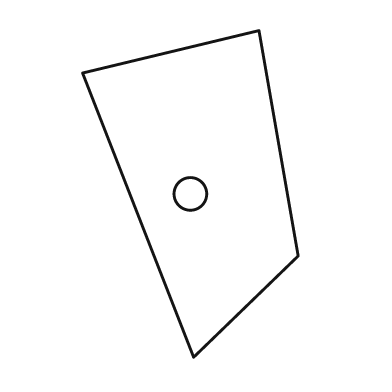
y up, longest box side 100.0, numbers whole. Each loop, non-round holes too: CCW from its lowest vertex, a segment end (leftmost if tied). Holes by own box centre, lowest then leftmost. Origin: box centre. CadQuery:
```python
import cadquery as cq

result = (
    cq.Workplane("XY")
    .moveTo(1.0, -50.0)
    .lineTo(33.0, -19.0)
    .lineTo(21.0, 50.0)
    .lineTo(-33.0, 37.0)
    .close()
    .moveTo(0.0, 0.0)
    .circle(5.0)
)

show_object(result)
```